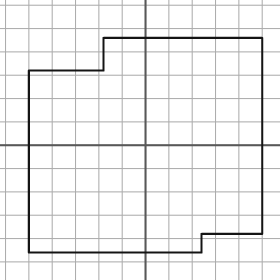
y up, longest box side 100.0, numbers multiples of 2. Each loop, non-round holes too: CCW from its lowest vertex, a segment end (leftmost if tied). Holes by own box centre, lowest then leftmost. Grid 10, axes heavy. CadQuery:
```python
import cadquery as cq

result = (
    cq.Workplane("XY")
    .moveTo(-50.0, -46.0)
    .lineTo(24.0, -46.0)
    .lineTo(24.0, -38.0)
    .lineTo(50.0, -38.0)
    .lineTo(50.0, 46.0)
    .lineTo(-18.0, 46.0)
    .lineTo(-18.0, 32.0)
    .lineTo(-50.0, 32.0)
    .close()
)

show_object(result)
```